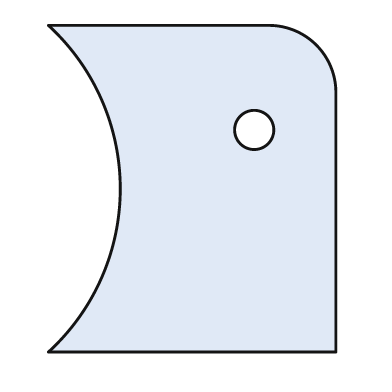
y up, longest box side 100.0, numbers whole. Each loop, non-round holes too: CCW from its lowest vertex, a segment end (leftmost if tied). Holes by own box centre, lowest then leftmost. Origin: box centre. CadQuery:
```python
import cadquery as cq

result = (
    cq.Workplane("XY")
    .moveTo(-44.0, -50.0)
    .lineTo(44.0, -50.0)
    .lineTo(44.0, 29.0)
    .threePointArc((38.0, 44.0), (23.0, 50.0))
    .lineTo(-44.0, 50.0)
    .threePointArc((-22.0, 0.0), (-44.0, -50.0))
    .close()
    .moveTo(19.0, 18.0)
    .circle(6.0)
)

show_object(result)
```